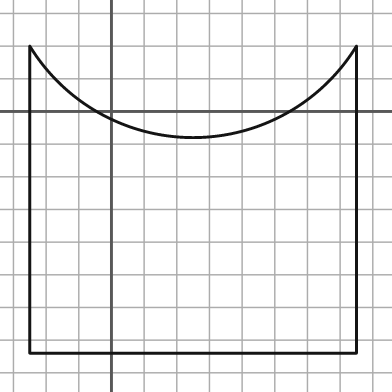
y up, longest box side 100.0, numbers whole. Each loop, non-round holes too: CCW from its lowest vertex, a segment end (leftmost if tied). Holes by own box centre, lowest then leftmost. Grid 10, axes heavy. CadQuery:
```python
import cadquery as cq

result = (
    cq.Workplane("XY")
    .moveTo(-25.0, -74.0)
    .lineTo(75.0, -74.0)
    .lineTo(75.0, 20.0)
    .threePointArc((25.0, -8.0), (-25.0, 20.0))
    .close()
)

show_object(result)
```